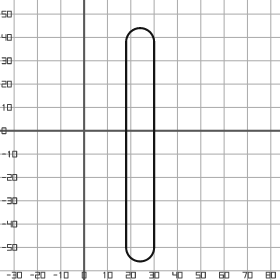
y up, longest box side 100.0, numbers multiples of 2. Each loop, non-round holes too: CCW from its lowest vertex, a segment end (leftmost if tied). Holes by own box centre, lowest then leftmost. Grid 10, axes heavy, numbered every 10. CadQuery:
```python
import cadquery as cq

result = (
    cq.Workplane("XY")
    .moveTo(18.0, -50.0)
    .threePointArc((24.0, -56.0), (30.0, -50.0))
    .lineTo(30.0, 38.0)
    .threePointArc((24.0, 44.0), (18.0, 38.0))
    .close()
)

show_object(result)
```